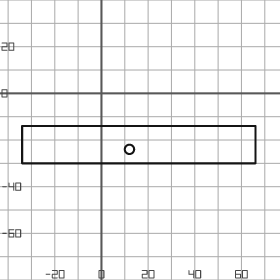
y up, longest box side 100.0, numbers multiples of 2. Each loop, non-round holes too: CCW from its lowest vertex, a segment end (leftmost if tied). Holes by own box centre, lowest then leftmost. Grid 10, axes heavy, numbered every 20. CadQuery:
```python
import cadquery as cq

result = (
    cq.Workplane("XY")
    .moveTo(-34.0, -30.0)
    .lineTo(66.0, -30.0)
    .lineTo(66.0, -14.0)
    .lineTo(-34.0, -14.0)
    .close()
    .moveTo(12.0, -24.0)
    .circle(2.0)
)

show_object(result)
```